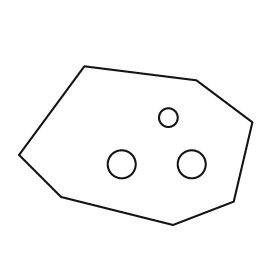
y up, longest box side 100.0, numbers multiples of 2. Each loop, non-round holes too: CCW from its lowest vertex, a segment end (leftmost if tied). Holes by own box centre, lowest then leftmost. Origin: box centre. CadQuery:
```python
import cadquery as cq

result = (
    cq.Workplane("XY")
    .moveTo(16.0, -34.0)
    .lineTo(42.0, -24.0)
    .lineTo(50.0, 10.0)
    .lineTo(26.0, 28.0)
    .lineTo(-22.0, 34.0)
    .lineTo(-50.0, -4.0)
    .lineTo(-32.0, -22.0)
    .close()
    .moveTo(-6.0, -8.0)
    .circle(6.0)
    .moveTo(24.0, -8.0)
    .circle(6.0)
    .moveTo(14.0, 12.0)
    .circle(4.0)
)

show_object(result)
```